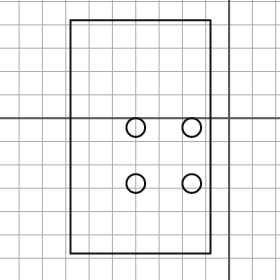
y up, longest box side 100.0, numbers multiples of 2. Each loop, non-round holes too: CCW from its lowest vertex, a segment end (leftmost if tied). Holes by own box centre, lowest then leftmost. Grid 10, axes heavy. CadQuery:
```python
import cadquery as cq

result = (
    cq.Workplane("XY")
    .moveTo(-68.0, -58.0)
    .lineTo(-8.0, -58.0)
    .lineTo(-8.0, 42.0)
    .lineTo(-68.0, 42.0)
    .close()
    .moveTo(-40.0, -28.0)
    .circle(4.0)
    .moveTo(-16.0, -28.0)
    .circle(4.0)
    .moveTo(-40.0, -4.0)
    .circle(4.0)
    .moveTo(-16.0, -4.0)
    .circle(4.0)
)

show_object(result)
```